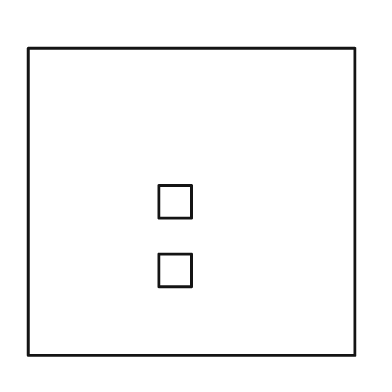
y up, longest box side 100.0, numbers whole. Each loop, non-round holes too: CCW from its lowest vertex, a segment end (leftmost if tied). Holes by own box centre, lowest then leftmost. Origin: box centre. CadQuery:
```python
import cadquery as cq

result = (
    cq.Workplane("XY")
    .moveTo(-50.0, -47.0)
    .lineTo(50.0, -47.0)
    .lineTo(50.0, 47.0)
    .lineTo(-50.0, 47.0)
    .close()
    .moveTo(-10.0, -26.0)
    .lineTo(0.0, -26.0)
    .lineTo(0.0, -16.0)
    .lineTo(-10.0, -16.0)
    .close()
    .moveTo(-10.0, -5.0)
    .lineTo(0.0, -5.0)
    .lineTo(0.0, 5.0)
    .lineTo(-10.0, 5.0)
    .close()
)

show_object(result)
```